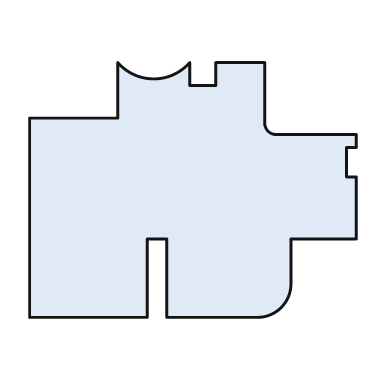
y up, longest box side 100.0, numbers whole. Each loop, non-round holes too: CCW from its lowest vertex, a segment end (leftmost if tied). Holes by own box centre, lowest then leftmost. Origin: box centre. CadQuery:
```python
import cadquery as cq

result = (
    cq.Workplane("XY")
    .moveTo(-50.0, -39.0)
    .lineTo(-14.0, -39.0)
    .lineTo(-14.0, -15.0)
    .lineTo(-8.0, -15.0)
    .lineTo(-8.0, -39.0)
    .lineTo(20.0, -39.0)
    .threePointArc((27.0, -36.0), (30.0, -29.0))
    .lineTo(30.0, -15.0)
    .lineTo(50.0, -15.0)
    .lineTo(50.0, 4.0)
    .lineTo(47.0, 4.0)
    .lineTo(47.0, 13.0)
    .lineTo(50.0, 13.0)
    .lineTo(50.0, 17.0)
    .lineTo(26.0, 17.0)
    .threePointArc((23.0, 18.0), (22.0, 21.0))
    .lineTo(22.0, 39.0)
    .lineTo(7.0, 39.0)
    .lineTo(7.0, 32.0)
    .lineTo(-1.0, 32.0)
    .lineTo(-1.0, 39.0)
    .threePointArc((-12.0, 34.0), (-23.0, 39.0))
    .lineTo(-23.0, 22.0)
    .lineTo(-50.0, 22.0)
    .close()
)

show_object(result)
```